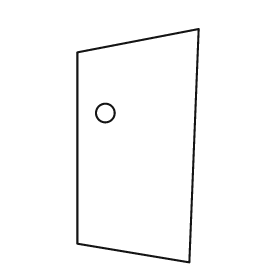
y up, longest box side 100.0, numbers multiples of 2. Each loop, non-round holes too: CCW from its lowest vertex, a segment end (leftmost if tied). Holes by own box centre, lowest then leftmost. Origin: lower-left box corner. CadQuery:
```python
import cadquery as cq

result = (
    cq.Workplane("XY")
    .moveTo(48.0, 0.0)
    .lineTo(52.0, 100.0)
    .lineTo(0.0, 90.0)
    .lineTo(0.0, 8.0)
    .close()
    .moveTo(12.0, 64.0)
    .circle(4.0)
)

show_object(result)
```